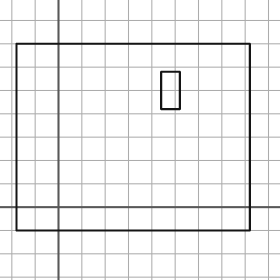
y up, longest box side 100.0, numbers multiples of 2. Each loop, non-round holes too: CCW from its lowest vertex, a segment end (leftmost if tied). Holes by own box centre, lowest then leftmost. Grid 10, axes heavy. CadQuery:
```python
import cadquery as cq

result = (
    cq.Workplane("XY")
    .moveTo(-18.0, -10.0)
    .lineTo(82.0, -10.0)
    .lineTo(82.0, 70.0)
    .lineTo(-18.0, 70.0)
    .close()
    .moveTo(44.0, 42.0)
    .lineTo(52.0, 42.0)
    .lineTo(52.0, 58.0)
    .lineTo(44.0, 58.0)
    .close()
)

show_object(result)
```